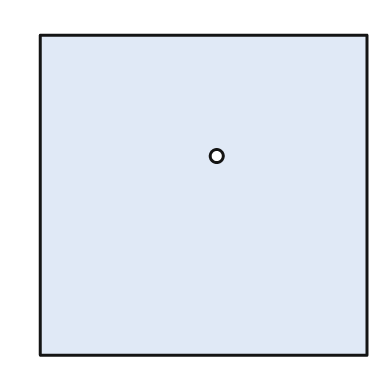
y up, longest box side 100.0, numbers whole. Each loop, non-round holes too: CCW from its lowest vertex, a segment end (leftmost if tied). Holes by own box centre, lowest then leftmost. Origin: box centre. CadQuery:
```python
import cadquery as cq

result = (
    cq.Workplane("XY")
    .moveTo(-50.0, -49.0)
    .lineTo(50.0, -49.0)
    .lineTo(50.0, 49.0)
    .lineTo(-50.0, 49.0)
    .close()
    .moveTo(4.0, 12.0)
    .circle(2.0)
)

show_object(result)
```